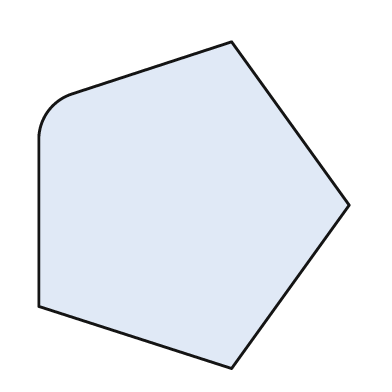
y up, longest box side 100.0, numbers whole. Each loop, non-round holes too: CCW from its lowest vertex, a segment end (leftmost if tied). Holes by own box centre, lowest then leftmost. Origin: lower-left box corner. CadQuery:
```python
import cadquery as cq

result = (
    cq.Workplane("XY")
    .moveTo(59.0, 0.0)
    .lineTo(95.0, 50.0)
    .lineTo(59.0, 100.0)
    .lineTo(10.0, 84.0)
    .threePointArc((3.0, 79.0), (0.0, 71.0))
    .lineTo(0.0, 19.0)
    .close()
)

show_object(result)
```